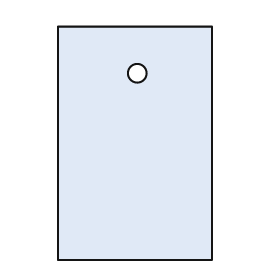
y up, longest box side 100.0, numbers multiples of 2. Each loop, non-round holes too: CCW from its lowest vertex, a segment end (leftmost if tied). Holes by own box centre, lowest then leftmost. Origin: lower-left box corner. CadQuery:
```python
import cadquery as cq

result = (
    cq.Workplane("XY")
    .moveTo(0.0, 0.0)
    .lineTo(66.0, 0.0)
    .lineTo(66.0, 100.0)
    .lineTo(0.0, 100.0)
    .close()
    .moveTo(34.0, 80.0)
    .circle(4.0)
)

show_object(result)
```